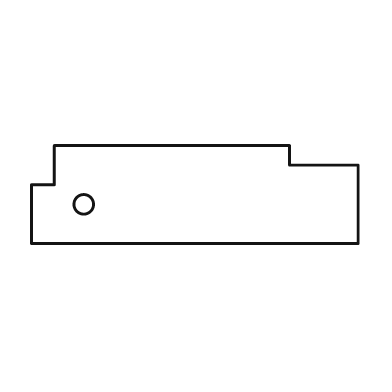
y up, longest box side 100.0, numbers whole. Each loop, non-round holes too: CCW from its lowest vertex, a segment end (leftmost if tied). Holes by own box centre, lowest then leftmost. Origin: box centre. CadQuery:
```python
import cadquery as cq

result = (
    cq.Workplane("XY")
    .moveTo(-50.0, -15.0)
    .lineTo(50.0, -15.0)
    .lineTo(50.0, 9.0)
    .lineTo(29.0, 9.0)
    .lineTo(29.0, 15.0)
    .lineTo(-43.0, 15.0)
    .lineTo(-43.0, 3.0)
    .lineTo(-50.0, 3.0)
    .close()
    .moveTo(-34.0, -3.0)
    .circle(3.0)
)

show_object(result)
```